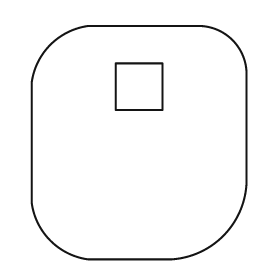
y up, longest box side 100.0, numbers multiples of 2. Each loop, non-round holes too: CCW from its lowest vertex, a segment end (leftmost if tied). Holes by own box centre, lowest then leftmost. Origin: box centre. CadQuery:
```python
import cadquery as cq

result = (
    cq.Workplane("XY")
    .moveTo(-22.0, -50.0)
    .lineTo(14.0, -50.0)
    .threePointArc((36.0, -40.0), (46.0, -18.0))
    .lineTo(46.0, 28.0)
    .threePointArc((40.0, 44.0), (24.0, 50.0))
    .lineTo(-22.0, 50.0)
    .threePointArc((-38.0, 42.0), (-46.0, 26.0))
    .lineTo(-46.0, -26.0)
    .threePointArc((-38.0, -42.0), (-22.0, -50.0))
    .close()
    .moveTo(-10.0, 14.0)
    .lineTo(10.0, 14.0)
    .lineTo(10.0, 34.0)
    .lineTo(-10.0, 34.0)
    .close()
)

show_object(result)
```